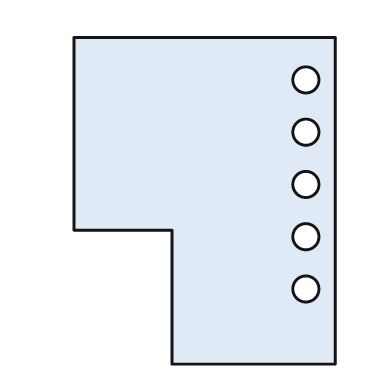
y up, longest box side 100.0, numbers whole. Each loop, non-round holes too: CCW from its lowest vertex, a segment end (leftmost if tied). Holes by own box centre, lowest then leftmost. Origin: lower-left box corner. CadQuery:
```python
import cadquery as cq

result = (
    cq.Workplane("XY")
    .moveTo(30.0, 0.0)
    .lineTo(80.0, 0.0)
    .lineTo(80.0, 100.0)
    .lineTo(0.0, 100.0)
    .lineTo(0.0, 41.0)
    .lineTo(30.0, 41.0)
    .close()
    .moveTo(71.0, 23.0)
    .circle(4.0)
    .moveTo(71.0, 39.0)
    .circle(4.0)
    .moveTo(71.0, 55.0)
    .circle(4.0)
    .moveTo(71.0, 71.0)
    .circle(4.0)
    .moveTo(71.0, 87.0)
    .circle(4.0)
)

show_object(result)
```